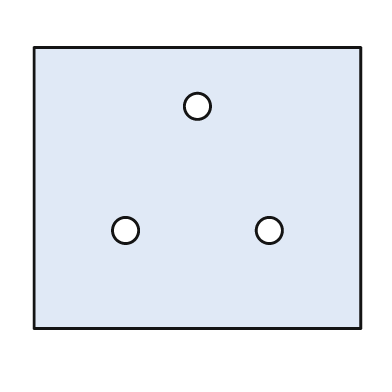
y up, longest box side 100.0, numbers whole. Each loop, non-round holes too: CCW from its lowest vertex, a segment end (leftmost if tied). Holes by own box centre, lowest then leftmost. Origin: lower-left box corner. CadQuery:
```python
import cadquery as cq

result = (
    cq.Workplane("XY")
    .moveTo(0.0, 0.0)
    .lineTo(100.0, 0.0)
    .lineTo(100.0, 86.0)
    .lineTo(0.0, 86.0)
    .close()
    .moveTo(28.0, 30.0)
    .circle(4.0)
    .moveTo(72.0, 30.0)
    .circle(4.0)
    .moveTo(50.0, 68.0)
    .circle(4.0)
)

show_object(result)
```